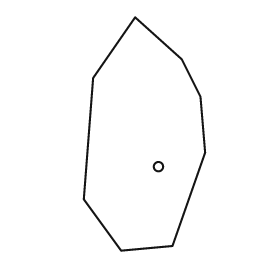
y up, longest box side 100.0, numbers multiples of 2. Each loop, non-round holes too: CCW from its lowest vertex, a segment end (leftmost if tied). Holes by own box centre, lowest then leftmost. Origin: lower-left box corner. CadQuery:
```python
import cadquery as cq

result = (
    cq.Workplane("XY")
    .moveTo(16.0, 0.0)
    .lineTo(38.0, 2.0)
    .lineTo(52.0, 42.0)
    .lineTo(50.0, 66.0)
    .lineTo(42.0, 82.0)
    .lineTo(22.0, 100.0)
    .lineTo(4.0, 74.0)
    .lineTo(0.0, 22.0)
    .close()
    .moveTo(32.0, 36.0)
    .circle(2.0)
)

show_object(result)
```